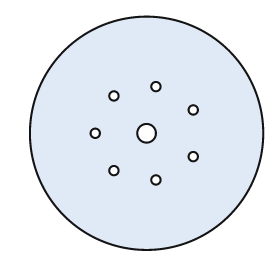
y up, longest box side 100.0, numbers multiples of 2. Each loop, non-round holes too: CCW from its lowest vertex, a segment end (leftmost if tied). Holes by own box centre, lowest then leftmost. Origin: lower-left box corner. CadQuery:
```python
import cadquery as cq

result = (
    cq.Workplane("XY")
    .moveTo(50.0, 50.0)
    .circle(50.0)
    .moveTo(54.0, 30.0)
    .circle(2.0)
    .moveTo(36.0, 34.0)
    .circle(2.0)
    .moveTo(70.0, 40.0)
    .circle(2.0)
    .moveTo(28.0, 50.0)
    .circle(2.0)
    .moveTo(50.0, 50.0)
    .circle(4.0)
    .moveTo(70.0, 60.0)
    .circle(2.0)
    .moveTo(36.0, 66.0)
    .circle(2.0)
    .moveTo(54.0, 70.0)
    .circle(2.0)
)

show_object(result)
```